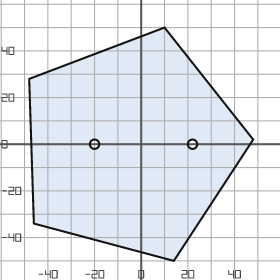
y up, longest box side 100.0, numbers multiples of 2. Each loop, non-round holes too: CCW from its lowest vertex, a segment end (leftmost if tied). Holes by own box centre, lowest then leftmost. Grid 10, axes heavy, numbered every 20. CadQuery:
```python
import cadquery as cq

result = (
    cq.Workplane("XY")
    .moveTo(14.0, -50.0)
    .lineTo(48.0, 2.0)
    .lineTo(10.0, 50.0)
    .lineTo(-48.0, 28.0)
    .lineTo(-46.0, -34.0)
    .close()
    .moveTo(-20.0, 0.0)
    .circle(2.0)
    .moveTo(22.0, 0.0)
    .circle(2.0)
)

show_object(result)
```